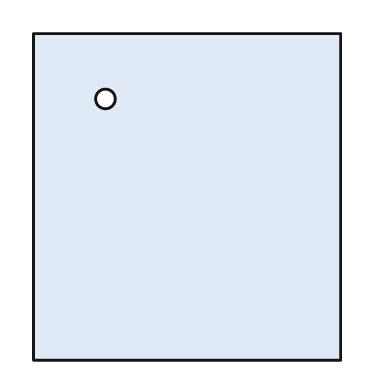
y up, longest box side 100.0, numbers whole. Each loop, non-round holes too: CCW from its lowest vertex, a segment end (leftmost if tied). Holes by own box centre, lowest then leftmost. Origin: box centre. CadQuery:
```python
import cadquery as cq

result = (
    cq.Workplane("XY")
    .moveTo(-47.0, -50.0)
    .lineTo(47.0, -50.0)
    .lineTo(47.0, 50.0)
    .lineTo(-47.0, 50.0)
    .close()
    .moveTo(-25.0, 30.0)
    .circle(3.0)
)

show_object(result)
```